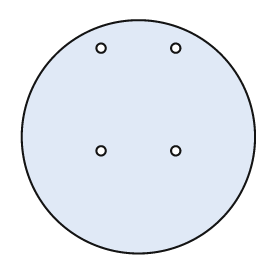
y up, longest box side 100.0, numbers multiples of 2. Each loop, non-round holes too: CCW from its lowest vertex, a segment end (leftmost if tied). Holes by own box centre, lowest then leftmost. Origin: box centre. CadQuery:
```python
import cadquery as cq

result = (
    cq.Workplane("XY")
    .moveTo(0.0, 0.0)
    .circle(50.0)
    .moveTo(-16.0, -6.0)
    .circle(2.0)
    .moveTo(16.0, -6.0)
    .circle(2.0)
    .moveTo(-16.0, 38.0)
    .circle(2.0)
    .moveTo(16.0, 38.0)
    .circle(2.0)
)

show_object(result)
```